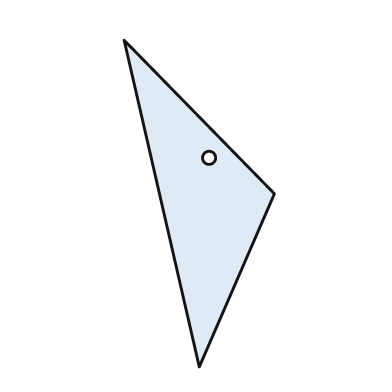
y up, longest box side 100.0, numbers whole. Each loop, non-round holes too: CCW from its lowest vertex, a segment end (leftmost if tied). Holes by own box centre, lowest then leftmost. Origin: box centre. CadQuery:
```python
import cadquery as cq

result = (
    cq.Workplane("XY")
    .moveTo(0.0, -50.0)
    .lineTo(23.0, 3.0)
    .lineTo(-23.0, 50.0)
    .close()
    .moveTo(3.0, 14.0)
    .circle(2.0)
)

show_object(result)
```